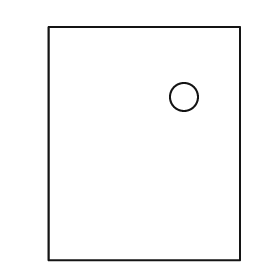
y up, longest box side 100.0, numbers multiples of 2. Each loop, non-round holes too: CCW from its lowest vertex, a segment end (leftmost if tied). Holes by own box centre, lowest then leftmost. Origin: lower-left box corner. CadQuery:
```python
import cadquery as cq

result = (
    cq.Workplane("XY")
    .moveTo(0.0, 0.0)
    .lineTo(82.0, 0.0)
    .lineTo(82.0, 100.0)
    .lineTo(0.0, 100.0)
    .close()
    .moveTo(58.0, 70.0)
    .circle(6.0)
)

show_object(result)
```